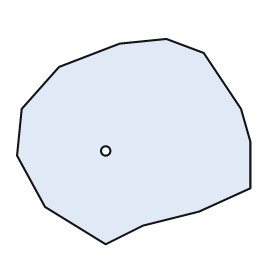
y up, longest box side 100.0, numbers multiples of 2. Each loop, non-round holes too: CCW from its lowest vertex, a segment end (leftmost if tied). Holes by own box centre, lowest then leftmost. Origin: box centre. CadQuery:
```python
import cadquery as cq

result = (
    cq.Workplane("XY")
    .moveTo(-12.0, -44.0)
    .lineTo(4.0, -36.0)
    .lineTo(28.0, -30.0)
    .lineTo(50.0, -20.0)
    .lineTo(50.0, 0.0)
    .lineTo(46.0, 14.0)
    .lineTo(30.0, 38.0)
    .lineTo(14.0, 44.0)
    .lineTo(-6.0, 42.0)
    .lineTo(-32.0, 32.0)
    .lineTo(-48.0, 14.0)
    .lineTo(-50.0, -6.0)
    .lineTo(-38.0, -28.0)
    .close()
    .moveTo(-12.0, -4.0)
    .circle(2.0)
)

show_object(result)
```